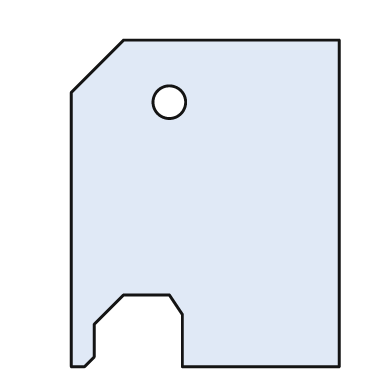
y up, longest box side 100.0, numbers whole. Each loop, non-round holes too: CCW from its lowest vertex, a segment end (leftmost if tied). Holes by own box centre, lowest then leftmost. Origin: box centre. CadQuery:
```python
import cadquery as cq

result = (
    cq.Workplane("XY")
    .moveTo(-41.0, -50.0)
    .lineTo(-37.0, -50.0)
    .lineTo(-34.0, -47.0)
    .lineTo(-34.0, -37.0)
    .lineTo(-25.0, -28.0)
    .lineTo(-11.0, -28.0)
    .lineTo(-7.0, -34.0)
    .lineTo(-7.0, -50.0)
    .lineTo(41.0, -50.0)
    .lineTo(41.0, 50.0)
    .lineTo(-25.0, 50.0)
    .lineTo(-41.0, 34.0)
    .close()
    .moveTo(-11.0, 31.0)
    .circle(5.0)
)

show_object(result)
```